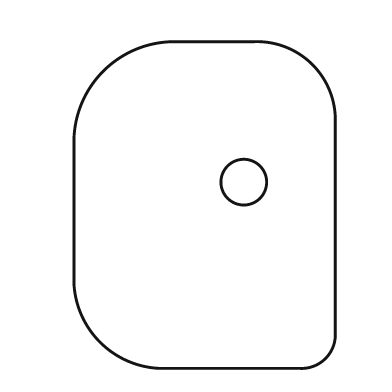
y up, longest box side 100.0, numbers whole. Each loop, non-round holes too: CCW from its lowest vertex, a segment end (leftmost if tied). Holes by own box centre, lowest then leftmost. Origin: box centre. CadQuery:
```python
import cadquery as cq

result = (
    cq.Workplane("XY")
    .moveTo(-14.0, -50.0)
    .lineTo(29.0, -50.0)
    .threePointArc((37.0, -47.0), (40.0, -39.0))
    .lineTo(40.0, 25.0)
    .threePointArc((33.0, 43.0), (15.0, 50.0))
    .lineTo(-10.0, 50.0)
    .threePointArc((-31.0, 41.0), (-40.0, 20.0))
    .lineTo(-40.0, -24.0)
    .threePointArc((-32.0, -42.0), (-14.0, -50.0))
    .close()
    .moveTo(12.0, 7.0)
    .circle(7.0)
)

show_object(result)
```